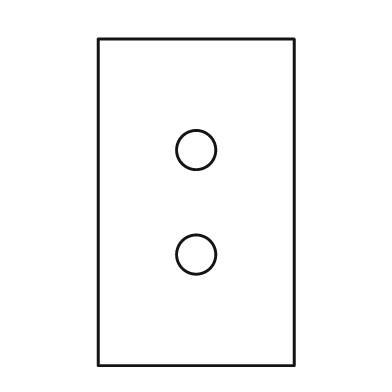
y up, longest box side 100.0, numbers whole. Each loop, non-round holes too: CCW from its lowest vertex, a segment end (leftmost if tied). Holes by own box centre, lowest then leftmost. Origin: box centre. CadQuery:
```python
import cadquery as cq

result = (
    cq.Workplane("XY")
    .moveTo(-30.0, -50.0)
    .lineTo(30.0, -50.0)
    .lineTo(30.0, 50.0)
    .lineTo(-30.0, 50.0)
    .close()
    .moveTo(0.0, -16.0)
    .circle(6.0)
    .moveTo(0.0, 16.0)
    .circle(6.0)
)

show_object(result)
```